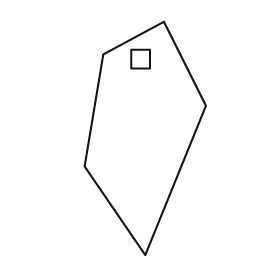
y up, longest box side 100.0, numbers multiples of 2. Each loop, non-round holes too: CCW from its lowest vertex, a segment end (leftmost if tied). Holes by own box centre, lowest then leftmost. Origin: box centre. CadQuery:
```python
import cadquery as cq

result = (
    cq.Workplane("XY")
    .moveTo(0.0, -50.0)
    .lineTo(26.0, 14.0)
    .lineTo(8.0, 50.0)
    .lineTo(-18.0, 36.0)
    .lineTo(-26.0, -12.0)
    .close()
    .moveTo(-6.0, 30.0)
    .lineTo(2.0, 30.0)
    .lineTo(2.0, 38.0)
    .lineTo(-6.0, 38.0)
    .close()
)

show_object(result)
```